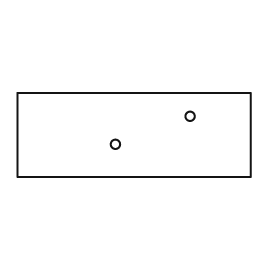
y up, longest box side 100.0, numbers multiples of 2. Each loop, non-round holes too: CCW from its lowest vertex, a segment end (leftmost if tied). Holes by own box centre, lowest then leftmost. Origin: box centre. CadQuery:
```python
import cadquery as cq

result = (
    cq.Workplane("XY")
    .moveTo(-50.0, -18.0)
    .lineTo(50.0, -18.0)
    .lineTo(50.0, 18.0)
    .lineTo(-50.0, 18.0)
    .close()
    .moveTo(-8.0, -4.0)
    .circle(2.0)
    .moveTo(24.0, 8.0)
    .circle(2.0)
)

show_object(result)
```